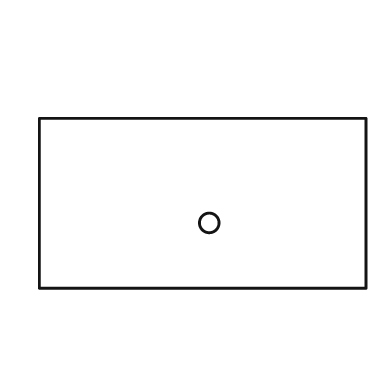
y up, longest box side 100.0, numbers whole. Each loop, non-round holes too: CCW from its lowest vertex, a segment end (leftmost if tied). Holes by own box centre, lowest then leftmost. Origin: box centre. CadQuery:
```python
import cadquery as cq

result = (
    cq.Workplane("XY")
    .moveTo(-50.0, -26.0)
    .lineTo(50.0, -26.0)
    .lineTo(50.0, 26.0)
    .lineTo(-50.0, 26.0)
    .close()
    .moveTo(2.0, -6.0)
    .circle(3.0)
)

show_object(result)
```